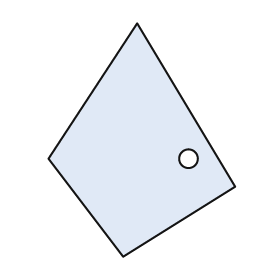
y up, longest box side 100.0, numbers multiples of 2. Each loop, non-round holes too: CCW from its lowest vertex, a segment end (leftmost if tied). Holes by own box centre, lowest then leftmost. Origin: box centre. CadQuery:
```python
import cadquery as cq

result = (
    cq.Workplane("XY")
    .moveTo(-8.0, -50.0)
    .lineTo(40.0, -20.0)
    .lineTo(-2.0, 50.0)
    .lineTo(-40.0, -8.0)
    .close()
    .moveTo(20.0, -8.0)
    .circle(4.0)
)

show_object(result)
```